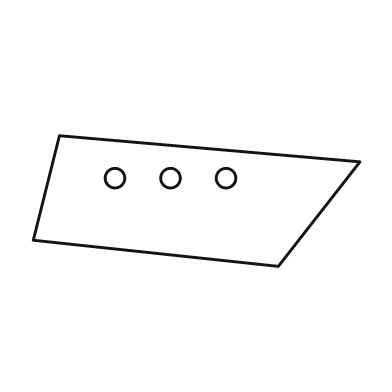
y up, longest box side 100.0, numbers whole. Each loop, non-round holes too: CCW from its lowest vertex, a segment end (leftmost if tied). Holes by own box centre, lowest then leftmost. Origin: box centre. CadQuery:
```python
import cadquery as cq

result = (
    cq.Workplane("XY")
    .moveTo(25.0, -20.0)
    .lineTo(50.0, 12.0)
    .lineTo(-42.0, 20.0)
    .lineTo(-50.0, -12.0)
    .close()
    .moveTo(-25.0, 7.0)
    .circle(3.0)
    .moveTo(-8.0, 7.0)
    .circle(3.0)
    .moveTo(9.0, 7.0)
    .circle(3.0)
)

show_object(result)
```